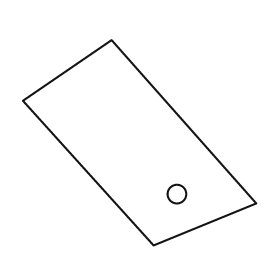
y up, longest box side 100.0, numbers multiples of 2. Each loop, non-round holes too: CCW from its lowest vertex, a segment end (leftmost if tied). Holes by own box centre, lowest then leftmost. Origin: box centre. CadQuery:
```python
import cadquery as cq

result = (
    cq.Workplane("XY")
    .moveTo(6.0, -44.0)
    .lineTo(50.0, -26.0)
    .lineTo(-12.0, 44.0)
    .lineTo(-50.0, 18.0)
    .close()
    .moveTo(16.0, -22.0)
    .circle(4.0)
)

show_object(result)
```